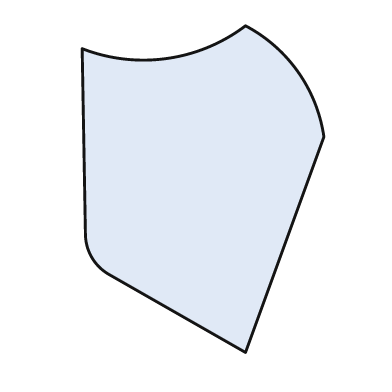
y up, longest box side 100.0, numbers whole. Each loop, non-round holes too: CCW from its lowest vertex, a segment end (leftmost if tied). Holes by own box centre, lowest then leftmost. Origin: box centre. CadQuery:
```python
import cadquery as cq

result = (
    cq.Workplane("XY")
    .moveTo(13.0, -50.0)
    .lineTo(37.0, 16.0)
    .threePointArc((29.0, 36.0), (13.0, 50.0))
    .threePointArc((-11.0, 40.0), (-37.0, 43.0))
    .lineTo(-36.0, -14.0)
    .threePointArc((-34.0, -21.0), (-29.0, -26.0))
    .close()
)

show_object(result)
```